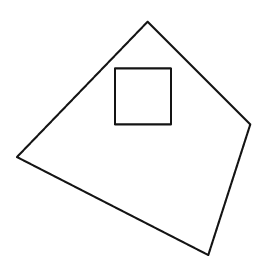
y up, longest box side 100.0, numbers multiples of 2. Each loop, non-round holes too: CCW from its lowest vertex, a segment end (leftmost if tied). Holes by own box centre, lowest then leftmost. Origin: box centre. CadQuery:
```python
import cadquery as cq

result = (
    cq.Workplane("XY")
    .moveTo(32.0, -50.0)
    .lineTo(50.0, 6.0)
    .lineTo(6.0, 50.0)
    .lineTo(-50.0, -8.0)
    .close()
    .moveTo(-8.0, 6.0)
    .lineTo(16.0, 6.0)
    .lineTo(16.0, 30.0)
    .lineTo(-8.0, 30.0)
    .close()
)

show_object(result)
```